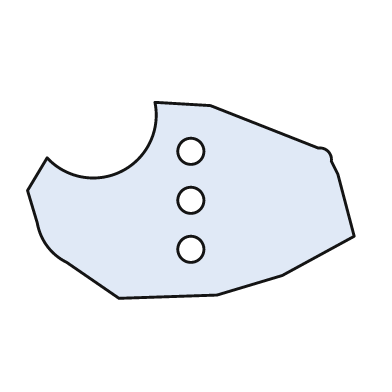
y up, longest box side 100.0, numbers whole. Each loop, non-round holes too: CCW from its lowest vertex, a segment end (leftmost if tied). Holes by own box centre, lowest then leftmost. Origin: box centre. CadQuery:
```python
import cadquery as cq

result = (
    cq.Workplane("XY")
    .moveTo(-22.0, -30.0)
    .lineTo(8.0, -29.0)
    .lineTo(28.0, -23.0)
    .lineTo(50.0, -11.0)
    .lineTo(45.0, 8.0)
    .lineTo(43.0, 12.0)
    .threePointArc((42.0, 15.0), (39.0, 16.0))
    .lineTo(6.0, 29.0)
    .lineTo(-11.0, 30.0)
    .threePointArc((-21.0, 9.0), (-44.0, 13.0))
    .lineTo(-50.0, 3.0)
    .lineTo(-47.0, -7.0)
    .threePointArc((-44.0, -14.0), (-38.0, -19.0))
    .close()
    .moveTo(0.0, -15.0)
    .circle(4.0)
    .moveTo(0.0, 0.0)
    .circle(4.0)
    .moveTo(0.0, 15.0)
    .circle(4.0)
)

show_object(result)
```